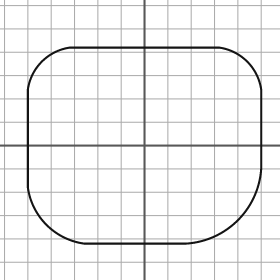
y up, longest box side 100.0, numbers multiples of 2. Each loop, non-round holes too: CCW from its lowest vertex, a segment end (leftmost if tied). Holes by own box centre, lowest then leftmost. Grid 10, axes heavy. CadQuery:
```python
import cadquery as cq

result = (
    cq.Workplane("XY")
    .moveTo(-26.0, -42.0)
    .lineTo(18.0, -42.0)
    .threePointArc((40.0, -32.0), (50.0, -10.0))
    .lineTo(50.0, 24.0)
    .threePointArc((44.0, 36.0), (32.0, 42.0))
    .lineTo(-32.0, 42.0)
    .threePointArc((-44.0, 36.0), (-50.0, 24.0))
    .lineTo(-50.0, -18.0)
    .threePointArc((-42.0, -34.0), (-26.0, -42.0))
    .close()
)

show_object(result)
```